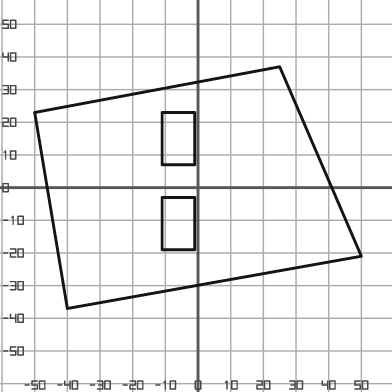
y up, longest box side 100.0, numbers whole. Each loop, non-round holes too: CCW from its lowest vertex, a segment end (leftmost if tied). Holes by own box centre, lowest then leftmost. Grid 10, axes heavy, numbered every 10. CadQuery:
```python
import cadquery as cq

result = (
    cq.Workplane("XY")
    .moveTo(-40.0, -37.0)
    .lineTo(50.0, -21.0)
    .lineTo(25.0, 37.0)
    .lineTo(-50.0, 23.0)
    .close()
    .moveTo(-11.0, -19.0)
    .lineTo(-1.0, -19.0)
    .lineTo(-1.0, -3.0)
    .lineTo(-11.0, -3.0)
    .close()
    .moveTo(-11.0, 7.0)
    .lineTo(-1.0, 7.0)
    .lineTo(-1.0, 23.0)
    .lineTo(-11.0, 23.0)
    .close()
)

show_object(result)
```